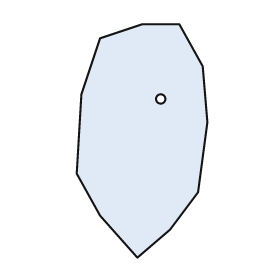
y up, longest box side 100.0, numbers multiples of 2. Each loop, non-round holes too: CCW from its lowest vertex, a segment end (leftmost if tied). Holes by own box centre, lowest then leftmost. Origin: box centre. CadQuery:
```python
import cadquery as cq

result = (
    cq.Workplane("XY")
    .moveTo(-2.0, -50.0)
    .lineTo(12.0, -38.0)
    .lineTo(24.0, -22.0)
    .lineTo(28.0, 8.0)
    .lineTo(26.0, 32.0)
    .lineTo(16.0, 50.0)
    .lineTo(0.0, 50.0)
    .lineTo(-18.0, 44.0)
    .lineTo(-26.0, 20.0)
    .lineTo(-28.0, -14.0)
    .lineTo(-18.0, -32.0)
    .close()
    .moveTo(8.0, 18.0)
    .circle(2.0)
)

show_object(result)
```